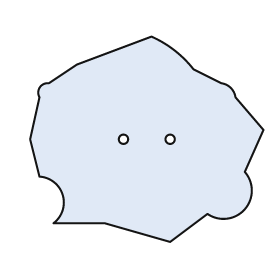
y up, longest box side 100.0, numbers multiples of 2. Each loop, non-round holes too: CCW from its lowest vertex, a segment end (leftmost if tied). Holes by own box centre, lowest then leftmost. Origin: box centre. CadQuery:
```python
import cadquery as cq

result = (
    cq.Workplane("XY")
    .moveTo(10.0, -44.0)
    .lineTo(26.0, -32.0)
    .threePointArc((42.0, -30.0), (42.0, -14.0))
    .lineTo(50.0, 4.0)
    .lineTo(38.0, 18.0)
    .threePointArc((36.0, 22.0), (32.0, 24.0))
    .lineTo(20.0, 30.0)
    .threePointArc((12.0, 38.0), (2.0, 44.0))
    .lineTo(-30.0, 32.0)
    .lineTo(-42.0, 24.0)
    .threePointArc((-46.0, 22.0), (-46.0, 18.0))
    .lineTo(-50.0, 0.0)
    .lineTo(-46.0, -16.0)
    .threePointArc((-36.0, -24.0), (-40.0, -36.0))
    .lineTo(-18.0, -36.0)
    .close()
    .moveTo(-10.0, 0.0)
    .circle(2.0)
    .moveTo(10.0, 0.0)
    .circle(2.0)
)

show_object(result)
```